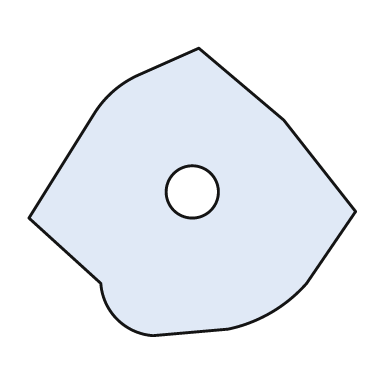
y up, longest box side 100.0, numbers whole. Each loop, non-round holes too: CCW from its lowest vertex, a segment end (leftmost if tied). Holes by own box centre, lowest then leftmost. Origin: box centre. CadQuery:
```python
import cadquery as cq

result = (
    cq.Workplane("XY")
    .moveTo(-12.0, -44.0)
    .lineTo(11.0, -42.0)
    .threePointArc((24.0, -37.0), (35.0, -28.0))
    .lineTo(50.0, -6.0)
    .lineTo(28.0, 22.0)
    .lineTo(2.0, 44.0)
    .lineTo(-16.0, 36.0)
    .threePointArc((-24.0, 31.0), (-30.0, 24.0))
    .lineTo(-50.0, -8.0)
    .lineTo(-28.0, -28.0)
    .threePointArc((-23.0, -39.0), (-12.0, -44.0))
    .close()
    .moveTo(0.0, 0.0)
    .circle(8.0)
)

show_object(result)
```